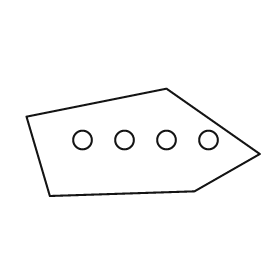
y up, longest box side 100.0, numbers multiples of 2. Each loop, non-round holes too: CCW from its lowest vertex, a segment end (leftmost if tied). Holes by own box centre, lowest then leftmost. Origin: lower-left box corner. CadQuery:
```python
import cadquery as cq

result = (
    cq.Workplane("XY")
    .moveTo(10.0, 0.0)
    .lineTo(72.0, 2.0)
    .lineTo(100.0, 18.0)
    .lineTo(60.0, 46.0)
    .lineTo(0.0, 34.0)
    .close()
    .moveTo(24.0, 24.0)
    .circle(4.0)
    .moveTo(42.0, 24.0)
    .circle(4.0)
    .moveTo(60.0, 24.0)
    .circle(4.0)
    .moveTo(78.0, 24.0)
    .circle(4.0)
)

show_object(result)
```